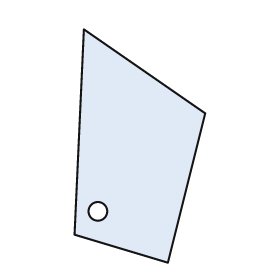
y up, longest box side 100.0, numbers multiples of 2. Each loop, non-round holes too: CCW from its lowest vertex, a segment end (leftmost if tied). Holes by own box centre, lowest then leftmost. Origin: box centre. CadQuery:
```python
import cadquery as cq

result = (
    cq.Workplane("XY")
    .moveTo(12.0, -50.0)
    .lineTo(28.0, 14.0)
    .lineTo(-24.0, 50.0)
    .lineTo(-28.0, -38.0)
    .close()
    .moveTo(-18.0, -28.0)
    .circle(4.0)
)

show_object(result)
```